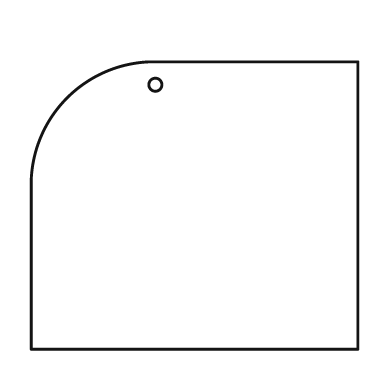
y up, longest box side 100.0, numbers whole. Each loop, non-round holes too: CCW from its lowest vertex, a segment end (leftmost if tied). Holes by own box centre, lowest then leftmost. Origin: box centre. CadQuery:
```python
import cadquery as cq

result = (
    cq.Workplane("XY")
    .moveTo(-50.0, -44.0)
    .lineTo(50.0, -44.0)
    .lineTo(50.0, 44.0)
    .lineTo(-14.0, 44.0)
    .threePointArc((-39.0, 33.0), (-50.0, 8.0))
    .close()
    .moveTo(-12.0, 37.0)
    .circle(2.0)
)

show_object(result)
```